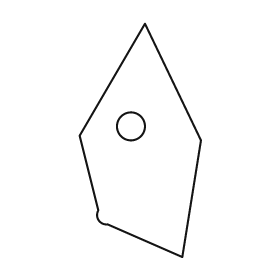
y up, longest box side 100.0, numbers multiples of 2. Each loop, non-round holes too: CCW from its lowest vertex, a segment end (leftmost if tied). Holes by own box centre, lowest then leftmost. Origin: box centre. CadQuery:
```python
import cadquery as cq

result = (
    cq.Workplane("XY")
    .moveTo(18.0, -50.0)
    .lineTo(26.0, 0.0)
    .lineTo(2.0, 50.0)
    .lineTo(-26.0, 2.0)
    .lineTo(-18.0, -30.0)
    .threePointArc((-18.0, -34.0), (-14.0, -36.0))
    .close()
    .moveTo(-4.0, 6.0)
    .circle(6.0)
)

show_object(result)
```